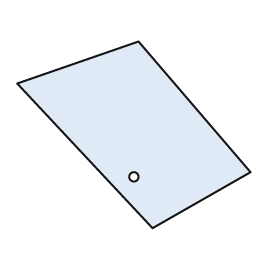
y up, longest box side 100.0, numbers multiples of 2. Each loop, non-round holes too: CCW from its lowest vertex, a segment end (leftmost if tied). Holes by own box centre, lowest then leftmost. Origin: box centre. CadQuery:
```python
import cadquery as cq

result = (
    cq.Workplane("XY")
    .moveTo(8.0, -40.0)
    .lineTo(50.0, -16.0)
    .lineTo(2.0, 40.0)
    .lineTo(-50.0, 22.0)
    .close()
    .moveTo(0.0, -18.0)
    .circle(2.0)
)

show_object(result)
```